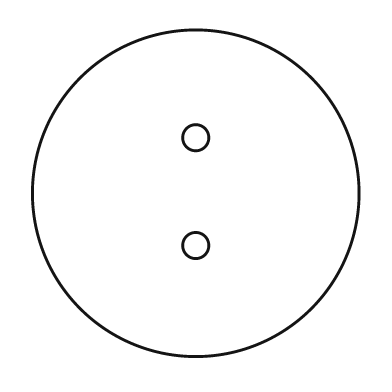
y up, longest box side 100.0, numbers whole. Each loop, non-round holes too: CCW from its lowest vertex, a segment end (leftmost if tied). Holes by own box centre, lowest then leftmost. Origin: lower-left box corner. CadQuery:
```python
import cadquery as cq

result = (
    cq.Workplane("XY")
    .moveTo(50.0, 50.0)
    .circle(50.0)
    .moveTo(50.0, 34.0)
    .circle(4.0)
    .moveTo(50.0, 67.0)
    .circle(4.0)
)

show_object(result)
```